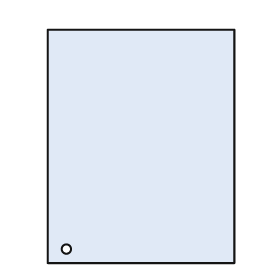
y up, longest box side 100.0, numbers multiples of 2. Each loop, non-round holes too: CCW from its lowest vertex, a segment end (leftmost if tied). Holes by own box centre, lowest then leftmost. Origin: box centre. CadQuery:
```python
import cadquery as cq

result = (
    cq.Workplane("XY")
    .moveTo(-40.0, -50.0)
    .lineTo(40.0, -50.0)
    .lineTo(40.0, 50.0)
    .lineTo(-40.0, 50.0)
    .close()
    .moveTo(-32.0, -44.0)
    .circle(2.0)
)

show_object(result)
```